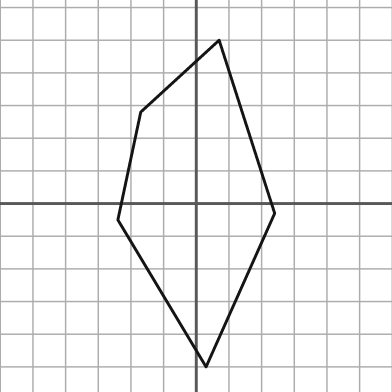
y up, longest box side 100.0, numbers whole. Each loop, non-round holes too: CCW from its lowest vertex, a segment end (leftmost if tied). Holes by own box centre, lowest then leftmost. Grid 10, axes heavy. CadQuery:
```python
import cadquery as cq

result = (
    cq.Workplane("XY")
    .moveTo(3.0, -50.0)
    .lineTo(24.0, -3.0)
    .lineTo(7.0, 50.0)
    .lineTo(-17.0, 28.0)
    .lineTo(-24.0, -5.0)
    .close()
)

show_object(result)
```